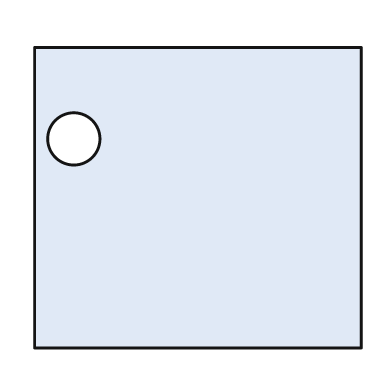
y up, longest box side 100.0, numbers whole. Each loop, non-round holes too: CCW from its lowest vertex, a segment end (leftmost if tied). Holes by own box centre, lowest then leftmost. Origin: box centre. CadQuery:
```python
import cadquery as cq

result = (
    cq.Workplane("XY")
    .moveTo(-50.0, -46.0)
    .lineTo(50.0, -46.0)
    .lineTo(50.0, 46.0)
    .lineTo(-50.0, 46.0)
    .close()
    .moveTo(-38.0, 18.0)
    .circle(8.0)
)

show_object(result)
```